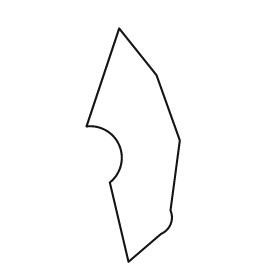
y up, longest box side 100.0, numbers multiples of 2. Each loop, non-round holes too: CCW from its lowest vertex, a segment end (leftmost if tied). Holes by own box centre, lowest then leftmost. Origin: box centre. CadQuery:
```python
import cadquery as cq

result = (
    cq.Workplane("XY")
    .moveTo(-2.0, -50.0)
    .lineTo(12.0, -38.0)
    .threePointArc((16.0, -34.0), (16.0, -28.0))
    .lineTo(20.0, 2.0)
    .lineTo(10.0, 30.0)
    .lineTo(-6.0, 50.0)
    .lineTo(-20.0, 8.0)
    .threePointArc((-6.0, 0.0), (-10.0, -16.0))
    .close()
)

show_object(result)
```